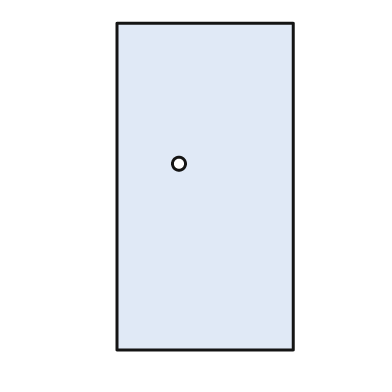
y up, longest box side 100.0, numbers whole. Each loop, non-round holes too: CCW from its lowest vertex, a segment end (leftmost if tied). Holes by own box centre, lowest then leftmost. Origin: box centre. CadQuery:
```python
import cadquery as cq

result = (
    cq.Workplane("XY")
    .moveTo(-27.0, -50.0)
    .lineTo(27.0, -50.0)
    .lineTo(27.0, 50.0)
    .lineTo(-27.0, 50.0)
    .close()
    .moveTo(-8.0, 7.0)
    .circle(2.0)
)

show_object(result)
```